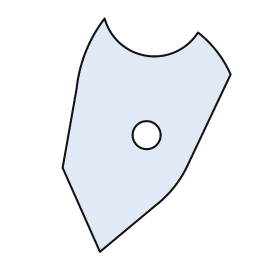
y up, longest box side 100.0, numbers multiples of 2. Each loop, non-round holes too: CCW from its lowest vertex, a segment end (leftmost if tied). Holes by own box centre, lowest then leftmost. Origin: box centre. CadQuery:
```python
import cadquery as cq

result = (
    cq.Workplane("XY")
    .moveTo(-20.0, -50.0)
    .lineTo(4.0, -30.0)
    .threePointArc((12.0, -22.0), (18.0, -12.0))
    .lineTo(36.0, 26.0)
    .threePointArc((30.0, 36.0), (22.0, 44.0))
    .threePointArc((0.0, 34.0), (-18.0, 50.0))
    .threePointArc((-26.0, 36.0), (-30.0, 20.0))
    .lineTo(-36.0, -14.0)
    .close()
    .moveTo(0.0, 0.0)
    .circle(6.0)
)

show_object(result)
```